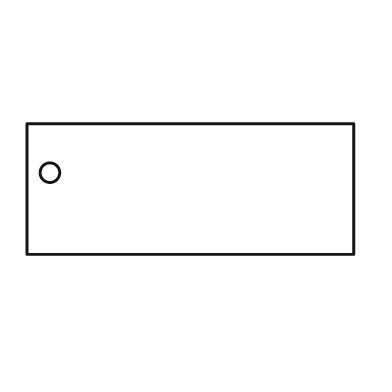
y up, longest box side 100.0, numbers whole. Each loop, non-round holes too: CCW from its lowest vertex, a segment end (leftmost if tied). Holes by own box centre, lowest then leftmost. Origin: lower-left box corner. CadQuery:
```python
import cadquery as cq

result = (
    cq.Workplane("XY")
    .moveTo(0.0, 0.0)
    .lineTo(100.0, 0.0)
    .lineTo(100.0, 40.0)
    .lineTo(0.0, 40.0)
    .close()
    .moveTo(7.0, 25.0)
    .circle(3.0)
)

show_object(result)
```